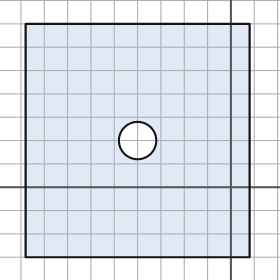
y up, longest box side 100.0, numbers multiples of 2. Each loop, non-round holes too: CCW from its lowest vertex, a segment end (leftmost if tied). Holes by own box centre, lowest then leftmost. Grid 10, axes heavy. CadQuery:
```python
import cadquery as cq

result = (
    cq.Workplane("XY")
    .moveTo(-88.0, -30.0)
    .lineTo(8.0, -30.0)
    .lineTo(8.0, 70.0)
    .lineTo(-88.0, 70.0)
    .close()
    .moveTo(-40.0, 20.0)
    .circle(8.0)
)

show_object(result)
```